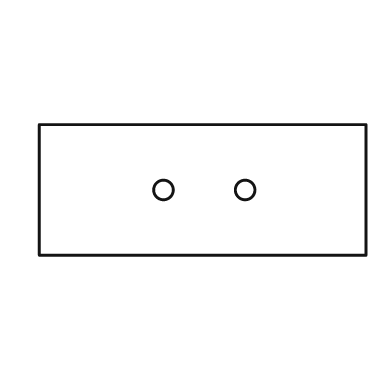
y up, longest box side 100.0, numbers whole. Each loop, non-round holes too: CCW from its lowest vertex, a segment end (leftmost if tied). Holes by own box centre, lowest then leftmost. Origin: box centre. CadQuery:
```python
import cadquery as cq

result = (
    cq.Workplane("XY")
    .moveTo(-50.0, -20.0)
    .lineTo(50.0, -20.0)
    .lineTo(50.0, 20.0)
    .lineTo(-50.0, 20.0)
    .close()
    .moveTo(-12.0, 0.0)
    .circle(3.0)
    .moveTo(13.0, 0.0)
    .circle(3.0)
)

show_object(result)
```